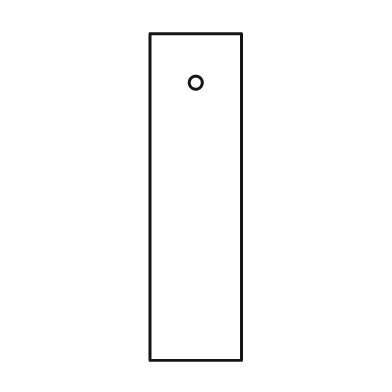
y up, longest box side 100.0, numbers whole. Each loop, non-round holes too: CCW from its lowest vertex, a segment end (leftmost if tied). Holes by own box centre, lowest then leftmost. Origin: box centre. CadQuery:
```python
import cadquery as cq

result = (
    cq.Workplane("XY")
    .moveTo(-14.0, -50.0)
    .lineTo(14.0, -50.0)
    .lineTo(14.0, 50.0)
    .lineTo(-14.0, 50.0)
    .close()
    .moveTo(0.0, 35.0)
    .circle(2.0)
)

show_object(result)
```